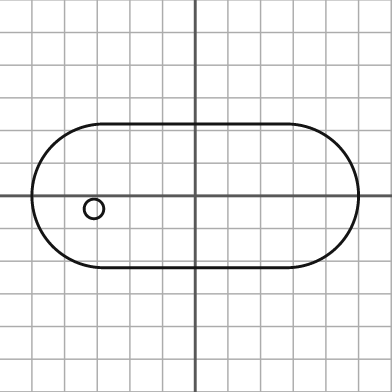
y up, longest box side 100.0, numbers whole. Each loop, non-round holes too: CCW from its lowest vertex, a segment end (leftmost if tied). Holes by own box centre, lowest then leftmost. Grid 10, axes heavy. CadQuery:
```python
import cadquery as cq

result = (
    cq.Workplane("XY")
    .moveTo(-28.0, -22.0)
    .lineTo(28.0, -22.0)
    .threePointArc((50.0, 0.0), (28.0, 22.0))
    .lineTo(-28.0, 22.0)
    .threePointArc((-50.0, 0.0), (-28.0, -22.0))
    .close()
    .moveTo(-31.0, -4.0)
    .circle(3.0)
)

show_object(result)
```